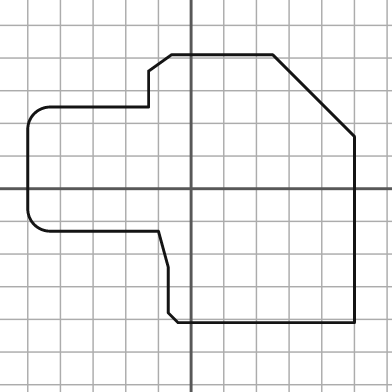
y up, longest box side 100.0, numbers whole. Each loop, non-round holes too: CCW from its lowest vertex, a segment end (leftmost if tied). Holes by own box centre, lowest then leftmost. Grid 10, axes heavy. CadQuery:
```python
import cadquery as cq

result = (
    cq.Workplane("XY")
    .moveTo(-4.0, -41.0)
    .lineTo(50.0, -41.0)
    .lineTo(50.0, 16.0)
    .lineTo(25.0, 41.0)
    .lineTo(-6.0, 41.0)
    .lineTo(-13.0, 36.0)
    .lineTo(-13.0, 25.0)
    .lineTo(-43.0, 25.0)
    .threePointArc((-48.0, 23.0), (-50.0, 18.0))
    .lineTo(-50.0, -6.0)
    .threePointArc((-48.0, -11.0), (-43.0, -13.0))
    .lineTo(-10.0, -13.0)
    .lineTo(-7.0, -24.0)
    .lineTo(-7.0, -38.0)
    .close()
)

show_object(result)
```